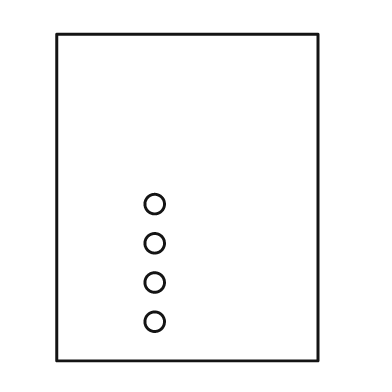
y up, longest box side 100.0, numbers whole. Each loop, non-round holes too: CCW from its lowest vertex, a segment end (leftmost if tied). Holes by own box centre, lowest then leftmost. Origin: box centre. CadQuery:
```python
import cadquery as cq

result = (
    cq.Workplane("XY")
    .moveTo(-40.0, -50.0)
    .lineTo(40.0, -50.0)
    .lineTo(40.0, 50.0)
    .lineTo(-40.0, 50.0)
    .close()
    .moveTo(-10.0, -38.0)
    .circle(3.0)
    .moveTo(-10.0, -26.0)
    .circle(3.0)
    .moveTo(-10.0, -14.0)
    .circle(3.0)
    .moveTo(-10.0, -2.0)
    .circle(3.0)
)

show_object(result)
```